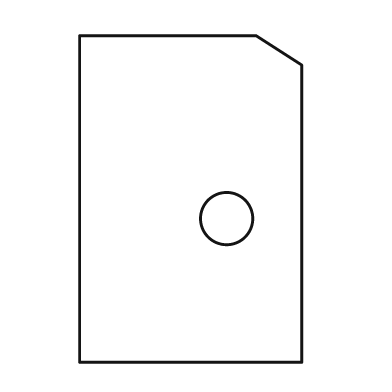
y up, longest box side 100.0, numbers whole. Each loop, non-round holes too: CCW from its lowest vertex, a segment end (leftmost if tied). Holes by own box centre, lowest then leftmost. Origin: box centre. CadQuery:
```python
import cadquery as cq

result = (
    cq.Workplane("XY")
    .moveTo(-34.0, -50.0)
    .lineTo(34.0, -50.0)
    .lineTo(34.0, 41.0)
    .lineTo(20.0, 50.0)
    .lineTo(-34.0, 50.0)
    .close()
    .moveTo(11.0, -6.0)
    .circle(8.0)
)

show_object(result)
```